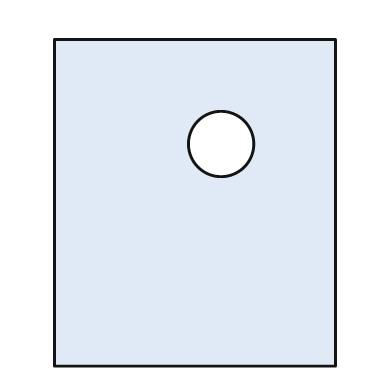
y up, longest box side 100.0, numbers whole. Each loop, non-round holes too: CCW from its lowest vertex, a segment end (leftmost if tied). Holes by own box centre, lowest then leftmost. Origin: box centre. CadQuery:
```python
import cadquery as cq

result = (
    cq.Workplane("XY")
    .moveTo(-43.0, -50.0)
    .lineTo(43.0, -50.0)
    .lineTo(43.0, 50.0)
    .lineTo(-43.0, 50.0)
    .close()
    .moveTo(8.0, 18.0)
    .circle(10.0)
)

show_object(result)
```